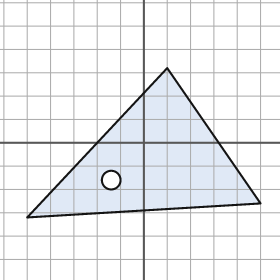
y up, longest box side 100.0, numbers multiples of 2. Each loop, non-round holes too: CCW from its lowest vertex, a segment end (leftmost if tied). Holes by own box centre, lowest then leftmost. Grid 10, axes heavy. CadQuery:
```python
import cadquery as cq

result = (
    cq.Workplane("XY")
    .moveTo(-50.0, -32.0)
    .lineTo(50.0, -26.0)
    .lineTo(10.0, 32.0)
    .close()
    .moveTo(-14.0, -16.0)
    .circle(4.0)
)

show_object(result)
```